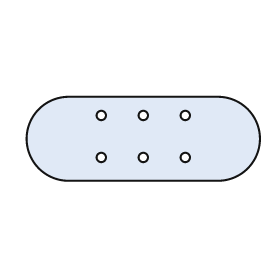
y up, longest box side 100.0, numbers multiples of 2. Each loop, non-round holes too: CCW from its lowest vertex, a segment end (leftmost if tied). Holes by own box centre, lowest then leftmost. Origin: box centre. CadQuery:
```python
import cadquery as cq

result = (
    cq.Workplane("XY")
    .moveTo(-32.0, -18.0)
    .lineTo(32.0, -18.0)
    .threePointArc((50.0, 0.0), (32.0, 18.0))
    .lineTo(-32.0, 18.0)
    .threePointArc((-50.0, 0.0), (-32.0, -18.0))
    .close()
    .moveTo(-18.0, -8.0)
    .circle(2.0)
    .moveTo(0.0, -8.0)
    .circle(2.0)
    .moveTo(18.0, -8.0)
    .circle(2.0)
    .moveTo(-18.0, 10.0)
    .circle(2.0)
    .moveTo(0.0, 10.0)
    .circle(2.0)
    .moveTo(18.0, 10.0)
    .circle(2.0)
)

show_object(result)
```